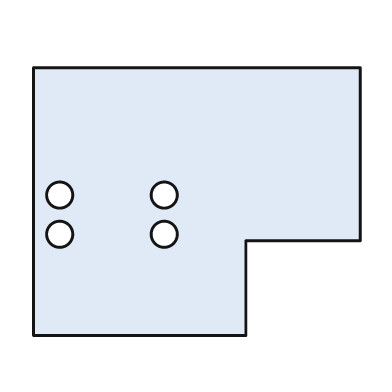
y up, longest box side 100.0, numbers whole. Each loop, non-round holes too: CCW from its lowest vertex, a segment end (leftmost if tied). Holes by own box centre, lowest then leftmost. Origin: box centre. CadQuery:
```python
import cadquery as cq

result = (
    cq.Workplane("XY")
    .moveTo(-50.0, -41.0)
    .lineTo(15.0, -41.0)
    .lineTo(15.0, -12.0)
    .lineTo(50.0, -12.0)
    .lineTo(50.0, 41.0)
    .lineTo(-50.0, 41.0)
    .close()
    .moveTo(-42.0, -10.0)
    .circle(4.0)
    .moveTo(-10.0, -10.0)
    .circle(4.0)
    .moveTo(-42.0, 2.0)
    .circle(4.0)
    .moveTo(-10.0, 2.0)
    .circle(4.0)
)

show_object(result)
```